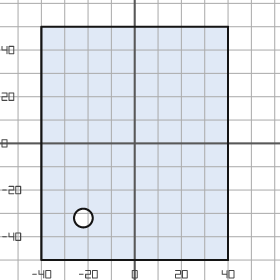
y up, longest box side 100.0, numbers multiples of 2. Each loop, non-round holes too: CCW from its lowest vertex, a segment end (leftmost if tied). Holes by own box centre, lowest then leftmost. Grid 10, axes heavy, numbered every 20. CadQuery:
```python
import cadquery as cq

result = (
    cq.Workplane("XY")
    .moveTo(-40.0, -50.0)
    .lineTo(40.0, -50.0)
    .lineTo(40.0, 50.0)
    .lineTo(-40.0, 50.0)
    .close()
    .moveTo(-22.0, -32.0)
    .circle(4.0)
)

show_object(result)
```